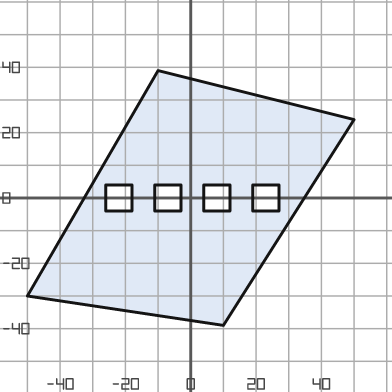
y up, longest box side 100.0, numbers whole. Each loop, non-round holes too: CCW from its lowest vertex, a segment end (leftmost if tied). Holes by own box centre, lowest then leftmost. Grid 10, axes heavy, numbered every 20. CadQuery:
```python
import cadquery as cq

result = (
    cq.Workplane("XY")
    .moveTo(10.0, -39.0)
    .lineTo(50.0, 24.0)
    .lineTo(-10.0, 39.0)
    .lineTo(-50.0, -30.0)
    .close()
    .moveTo(-26.0, -4.0)
    .lineTo(-18.0, -4.0)
    .lineTo(-18.0, 4.0)
    .lineTo(-26.0, 4.0)
    .close()
    .moveTo(-11.0, -4.0)
    .lineTo(-3.0, -4.0)
    .lineTo(-3.0, 4.0)
    .lineTo(-11.0, 4.0)
    .close()
    .moveTo(4.0, -4.0)
    .lineTo(12.0, -4.0)
    .lineTo(12.0, 4.0)
    .lineTo(4.0, 4.0)
    .close()
    .moveTo(19.0, -4.0)
    .lineTo(27.0, -4.0)
    .lineTo(27.0, 4.0)
    .lineTo(19.0, 4.0)
    .close()
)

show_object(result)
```